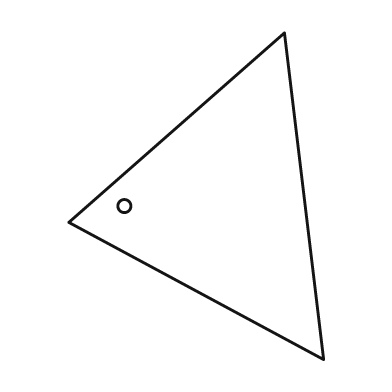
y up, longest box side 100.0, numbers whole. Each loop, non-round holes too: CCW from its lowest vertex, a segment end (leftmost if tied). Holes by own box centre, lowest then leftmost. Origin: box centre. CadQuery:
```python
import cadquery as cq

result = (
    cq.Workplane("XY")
    .moveTo(39.0, -50.0)
    .lineTo(27.0, 50.0)
    .lineTo(-39.0, -8.0)
    .close()
    .moveTo(-22.0, -3.0)
    .circle(2.0)
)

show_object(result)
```